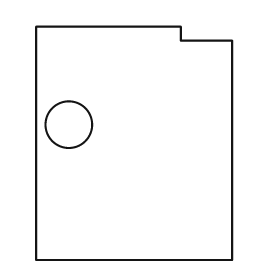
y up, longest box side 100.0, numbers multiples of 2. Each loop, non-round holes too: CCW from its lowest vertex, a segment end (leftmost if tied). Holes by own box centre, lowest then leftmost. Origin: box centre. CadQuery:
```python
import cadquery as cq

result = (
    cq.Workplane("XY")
    .moveTo(-42.0, -50.0)
    .lineTo(42.0, -50.0)
    .lineTo(42.0, 44.0)
    .lineTo(20.0, 44.0)
    .lineTo(20.0, 50.0)
    .lineTo(-42.0, 50.0)
    .close()
    .moveTo(-28.0, 8.0)
    .circle(10.0)
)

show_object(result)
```